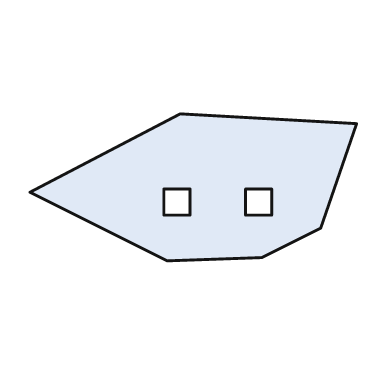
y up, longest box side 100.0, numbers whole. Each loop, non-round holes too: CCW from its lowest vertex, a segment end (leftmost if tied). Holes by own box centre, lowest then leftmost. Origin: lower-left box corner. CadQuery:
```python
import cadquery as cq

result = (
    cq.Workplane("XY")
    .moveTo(42.0, 0.0)
    .lineTo(71.0, 1.0)
    .lineTo(89.0, 10.0)
    .lineTo(100.0, 42.0)
    .lineTo(46.0, 45.0)
    .lineTo(0.0, 21.0)
    .close()
    .moveTo(41.0, 14.0)
    .lineTo(49.0, 14.0)
    .lineTo(49.0, 22.0)
    .lineTo(41.0, 22.0)
    .close()
    .moveTo(66.0, 14.0)
    .lineTo(74.0, 14.0)
    .lineTo(74.0, 22.0)
    .lineTo(66.0, 22.0)
    .close()
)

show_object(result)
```